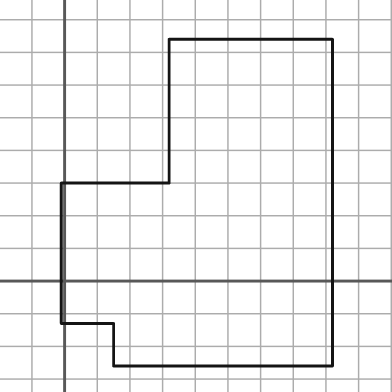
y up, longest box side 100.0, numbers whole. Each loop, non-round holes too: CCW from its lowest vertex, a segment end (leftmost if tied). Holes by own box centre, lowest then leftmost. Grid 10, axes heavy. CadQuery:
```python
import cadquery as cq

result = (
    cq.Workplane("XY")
    .moveTo(15.0, -26.0)
    .lineTo(82.0, -26.0)
    .lineTo(82.0, 74.0)
    .lineTo(32.0, 74.0)
    .lineTo(32.0, 30.0)
    .lineTo(-1.0, 30.0)
    .lineTo(-1.0, -13.0)
    .lineTo(15.0, -13.0)
    .close()
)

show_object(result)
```